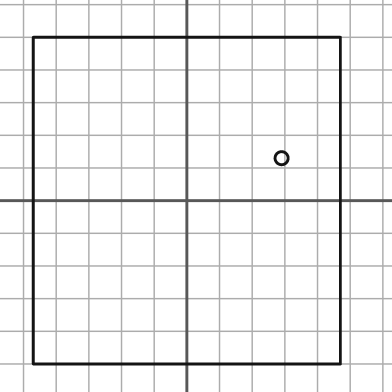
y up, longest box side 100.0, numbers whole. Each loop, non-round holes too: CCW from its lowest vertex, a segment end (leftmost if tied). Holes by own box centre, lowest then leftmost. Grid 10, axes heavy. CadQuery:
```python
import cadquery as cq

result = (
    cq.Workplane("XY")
    .moveTo(-47.0, -50.0)
    .lineTo(47.0, -50.0)
    .lineTo(47.0, 50.0)
    .lineTo(-47.0, 50.0)
    .close()
    .moveTo(29.0, 13.0)
    .circle(2.0)
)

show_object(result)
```